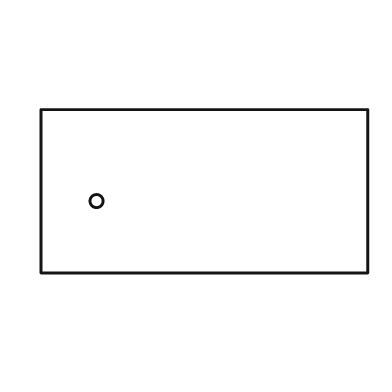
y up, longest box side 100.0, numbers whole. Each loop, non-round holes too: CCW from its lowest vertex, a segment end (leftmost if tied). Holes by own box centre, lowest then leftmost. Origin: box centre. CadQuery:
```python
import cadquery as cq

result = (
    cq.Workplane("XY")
    .moveTo(-50.0, -25.0)
    .lineTo(50.0, -25.0)
    .lineTo(50.0, 25.0)
    .lineTo(-50.0, 25.0)
    .close()
    .moveTo(-33.0, -3.0)
    .circle(2.0)
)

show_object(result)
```